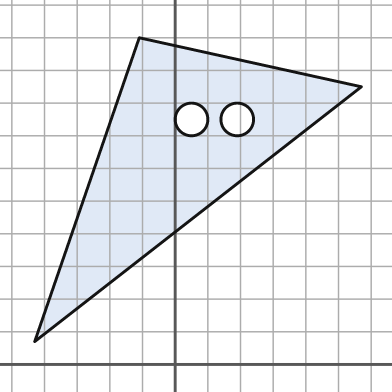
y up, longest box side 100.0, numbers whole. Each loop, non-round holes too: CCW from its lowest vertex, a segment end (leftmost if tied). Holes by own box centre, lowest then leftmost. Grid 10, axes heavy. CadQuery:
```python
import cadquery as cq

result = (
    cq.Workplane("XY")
    .moveTo(-43.0, 7.0)
    .lineTo(57.0, 85.0)
    .lineTo(-11.0, 100.0)
    .close()
    .moveTo(5.0, 75.0)
    .circle(5.0)
    .moveTo(19.0, 75.0)
    .circle(5.0)
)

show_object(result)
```